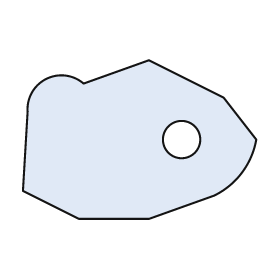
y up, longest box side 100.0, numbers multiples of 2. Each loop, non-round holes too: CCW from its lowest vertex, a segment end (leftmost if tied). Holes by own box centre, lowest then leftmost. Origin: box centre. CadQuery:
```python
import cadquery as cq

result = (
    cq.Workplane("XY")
    .moveTo(-26.0, -34.0)
    .lineTo(4.0, -34.0)
    .lineTo(32.0, -24.0)
    .threePointArc((44.0, -14.0), (50.0, 0.0))
    .lineTo(36.0, 18.0)
    .lineTo(4.0, 34.0)
    .lineTo(-24.0, 24.0)
    .threePointArc((-40.0, 26.0), (-48.0, 12.0))
    .lineTo(-50.0, -22.0)
    .close()
    .moveTo(18.0, 0.0)
    .circle(8.0)
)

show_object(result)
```